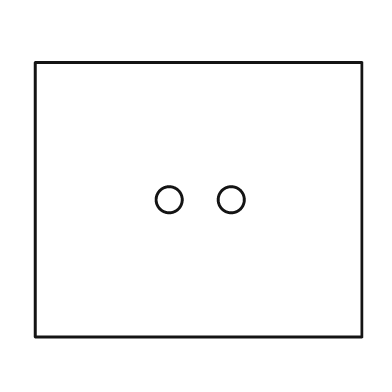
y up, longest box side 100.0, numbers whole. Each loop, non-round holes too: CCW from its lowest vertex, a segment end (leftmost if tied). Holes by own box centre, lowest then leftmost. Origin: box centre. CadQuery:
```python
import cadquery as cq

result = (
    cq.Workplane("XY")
    .moveTo(-50.0, -42.0)
    .lineTo(50.0, -42.0)
    .lineTo(50.0, 42.0)
    .lineTo(-50.0, 42.0)
    .close()
    .moveTo(-9.0, 0.0)
    .circle(4.0)
    .moveTo(10.0, 0.0)
    .circle(4.0)
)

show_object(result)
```